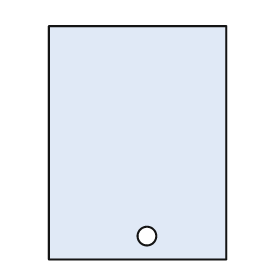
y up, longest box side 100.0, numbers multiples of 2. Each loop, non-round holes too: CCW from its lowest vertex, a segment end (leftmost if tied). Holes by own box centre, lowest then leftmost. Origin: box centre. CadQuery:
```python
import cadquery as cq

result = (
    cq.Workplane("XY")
    .moveTo(-38.0, -50.0)
    .lineTo(38.0, -50.0)
    .lineTo(38.0, 50.0)
    .lineTo(-38.0, 50.0)
    .close()
    .moveTo(4.0, -40.0)
    .circle(4.0)
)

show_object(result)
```